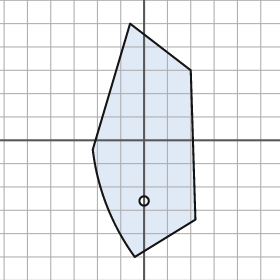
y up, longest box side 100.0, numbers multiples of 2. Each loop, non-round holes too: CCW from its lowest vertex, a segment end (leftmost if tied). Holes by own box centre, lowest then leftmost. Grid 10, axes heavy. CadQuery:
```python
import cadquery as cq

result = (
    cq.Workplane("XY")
    .moveTo(-4.0, -50.0)
    .lineTo(22.0, -34.0)
    .lineTo(20.0, 30.0)
    .lineTo(-6.0, 50.0)
    .lineTo(-22.0, -4.0)
    .threePointArc((-16.0, -28.0), (-4.0, -50.0))
    .close()
    .moveTo(0.0, -26.0)
    .circle(2.0)
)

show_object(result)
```